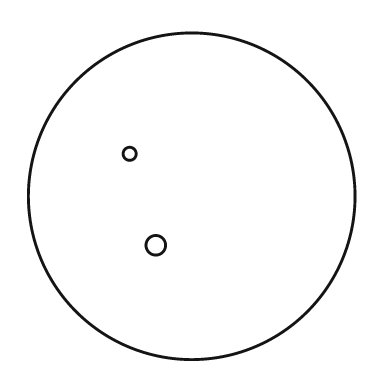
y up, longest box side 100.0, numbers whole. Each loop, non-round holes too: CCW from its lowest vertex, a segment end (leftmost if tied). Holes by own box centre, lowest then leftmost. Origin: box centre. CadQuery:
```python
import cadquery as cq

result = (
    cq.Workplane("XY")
    .moveTo(0.0, 0.0)
    .circle(50.0)
    .moveTo(-11.0, -15.0)
    .circle(3.0)
    .moveTo(-19.0, 13.0)
    .circle(2.0)
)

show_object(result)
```